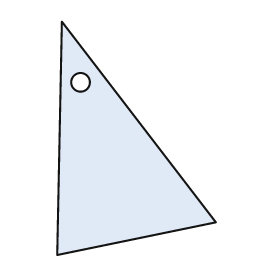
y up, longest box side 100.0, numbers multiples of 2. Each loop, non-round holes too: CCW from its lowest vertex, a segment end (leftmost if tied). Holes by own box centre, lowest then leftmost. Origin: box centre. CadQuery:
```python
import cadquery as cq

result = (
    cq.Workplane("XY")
    .moveTo(-34.0, -50.0)
    .lineTo(34.0, -36.0)
    .lineTo(-32.0, 50.0)
    .close()
    .moveTo(-24.0, 24.0)
    .circle(4.0)
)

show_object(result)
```